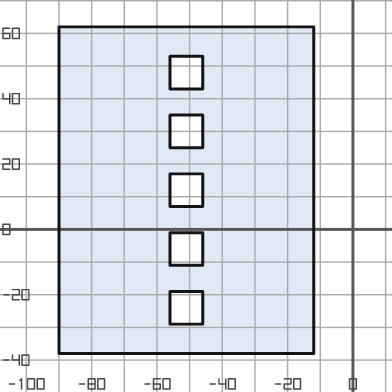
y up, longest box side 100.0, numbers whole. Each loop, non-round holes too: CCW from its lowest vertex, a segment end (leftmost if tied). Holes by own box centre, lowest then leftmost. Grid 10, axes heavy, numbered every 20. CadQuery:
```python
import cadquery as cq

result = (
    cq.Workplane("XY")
    .moveTo(-90.0, -38.0)
    .lineTo(-12.0, -38.0)
    .lineTo(-12.0, 62.0)
    .lineTo(-90.0, 62.0)
    .close()
    .moveTo(-56.0, -29.0)
    .lineTo(-46.0, -29.0)
    .lineTo(-46.0, -19.0)
    .lineTo(-56.0, -19.0)
    .close()
    .moveTo(-56.0, -11.0)
    .lineTo(-46.0, -11.0)
    .lineTo(-46.0, -1.0)
    .lineTo(-56.0, -1.0)
    .close()
    .moveTo(-56.0, 7.0)
    .lineTo(-46.0, 7.0)
    .lineTo(-46.0, 17.0)
    .lineTo(-56.0, 17.0)
    .close()
    .moveTo(-56.0, 25.0)
    .lineTo(-46.0, 25.0)
    .lineTo(-46.0, 35.0)
    .lineTo(-56.0, 35.0)
    .close()
    .moveTo(-56.0, 43.0)
    .lineTo(-46.0, 43.0)
    .lineTo(-46.0, 53.0)
    .lineTo(-56.0, 53.0)
    .close()
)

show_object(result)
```